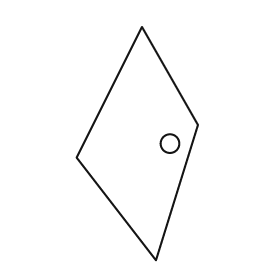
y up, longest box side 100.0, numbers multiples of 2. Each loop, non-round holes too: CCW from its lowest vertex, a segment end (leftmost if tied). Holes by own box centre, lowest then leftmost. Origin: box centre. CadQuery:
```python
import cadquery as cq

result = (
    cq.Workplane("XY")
    .moveTo(8.0, -50.0)
    .lineTo(26.0, 8.0)
    .lineTo(2.0, 50.0)
    .lineTo(-26.0, -6.0)
    .close()
    .moveTo(14.0, 0.0)
    .circle(4.0)
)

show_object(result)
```